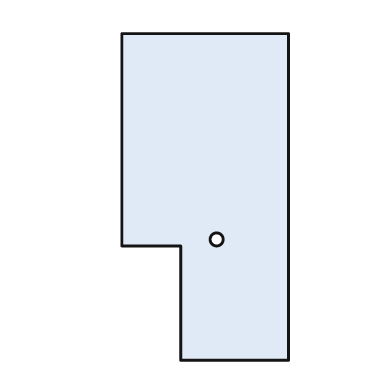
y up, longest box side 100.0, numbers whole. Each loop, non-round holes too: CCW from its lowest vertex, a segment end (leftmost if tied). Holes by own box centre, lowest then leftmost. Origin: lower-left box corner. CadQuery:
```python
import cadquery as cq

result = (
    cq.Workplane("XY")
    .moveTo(18.0, 0.0)
    .lineTo(51.0, 0.0)
    .lineTo(51.0, 100.0)
    .lineTo(0.0, 100.0)
    .lineTo(0.0, 35.0)
    .lineTo(18.0, 35.0)
    .close()
    .moveTo(29.0, 37.0)
    .circle(2.0)
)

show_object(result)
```